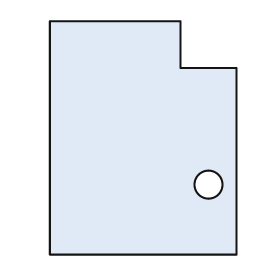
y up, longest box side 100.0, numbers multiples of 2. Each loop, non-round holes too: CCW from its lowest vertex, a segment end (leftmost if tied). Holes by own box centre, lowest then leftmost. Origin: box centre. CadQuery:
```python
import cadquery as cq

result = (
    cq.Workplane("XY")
    .moveTo(-40.0, -50.0)
    .lineTo(40.0, -50.0)
    .lineTo(40.0, 30.0)
    .lineTo(16.0, 30.0)
    .lineTo(16.0, 50.0)
    .lineTo(-40.0, 50.0)
    .close()
    .moveTo(28.0, -20.0)
    .circle(6.0)
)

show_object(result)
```